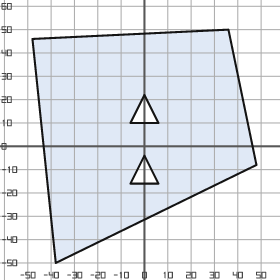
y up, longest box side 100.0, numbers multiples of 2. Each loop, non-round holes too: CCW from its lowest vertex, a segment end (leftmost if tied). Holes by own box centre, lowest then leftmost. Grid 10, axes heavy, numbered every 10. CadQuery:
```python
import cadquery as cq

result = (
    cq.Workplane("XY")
    .moveTo(-38.0, -50.0)
    .lineTo(48.0, -8.0)
    .lineTo(36.0, 50.0)
    .lineTo(-48.0, 46.0)
    .close()
    .moveTo(-6.0, -16.0)
    .lineTo(6.0, -16.0)
    .lineTo(0.0, -4.0)
    .close()
    .moveTo(-6.0, 10.0)
    .lineTo(6.0, 10.0)
    .lineTo(0.0, 22.0)
    .close()
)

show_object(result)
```